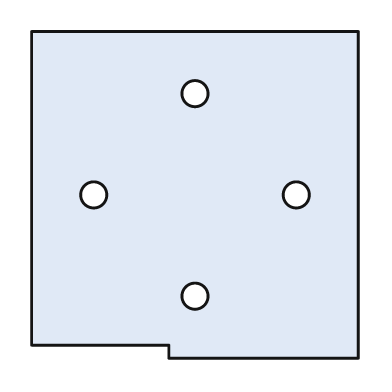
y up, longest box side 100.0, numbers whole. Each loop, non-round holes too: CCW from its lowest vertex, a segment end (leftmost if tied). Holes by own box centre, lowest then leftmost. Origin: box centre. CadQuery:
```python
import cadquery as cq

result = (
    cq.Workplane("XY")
    .moveTo(-8.0, -50.0)
    .lineTo(50.0, -50.0)
    .lineTo(50.0, 50.0)
    .lineTo(-50.0, 50.0)
    .lineTo(-50.0, -46.0)
    .lineTo(-8.0, -46.0)
    .close()
    .moveTo(0.0, -31.0)
    .circle(4.0)
    .moveTo(-31.0, 0.0)
    .circle(4.0)
    .moveTo(31.0, 0.0)
    .circle(4.0)
    .moveTo(0.0, 31.0)
    .circle(4.0)
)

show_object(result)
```